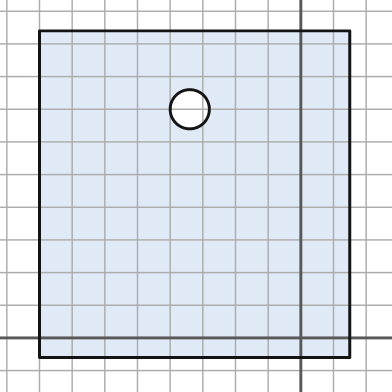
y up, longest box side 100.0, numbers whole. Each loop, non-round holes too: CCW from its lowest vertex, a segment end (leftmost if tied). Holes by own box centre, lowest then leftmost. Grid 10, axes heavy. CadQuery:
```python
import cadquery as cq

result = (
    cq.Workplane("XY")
    .moveTo(-80.0, -6.0)
    .lineTo(15.0, -6.0)
    .lineTo(15.0, 94.0)
    .lineTo(-80.0, 94.0)
    .close()
    .moveTo(-34.0, 70.0)
    .circle(6.0)
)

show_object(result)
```